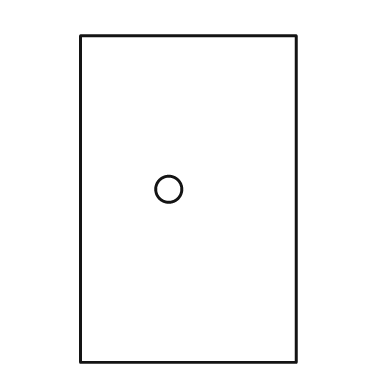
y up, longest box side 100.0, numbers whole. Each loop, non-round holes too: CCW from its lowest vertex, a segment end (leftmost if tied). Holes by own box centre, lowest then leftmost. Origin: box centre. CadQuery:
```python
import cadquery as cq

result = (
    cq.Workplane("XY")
    .moveTo(-33.0, -50.0)
    .lineTo(33.0, -50.0)
    .lineTo(33.0, 50.0)
    .lineTo(-33.0, 50.0)
    .close()
    .moveTo(-6.0, 3.0)
    .circle(4.0)
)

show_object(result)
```